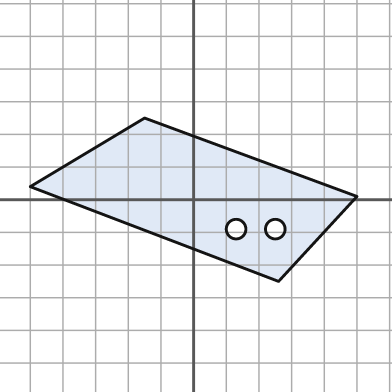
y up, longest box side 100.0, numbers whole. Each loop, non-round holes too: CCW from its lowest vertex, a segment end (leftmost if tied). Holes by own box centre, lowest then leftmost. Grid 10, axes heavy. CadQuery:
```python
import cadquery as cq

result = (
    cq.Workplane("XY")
    .moveTo(26.0, -25.0)
    .lineTo(50.0, 1.0)
    .lineTo(-15.0, 25.0)
    .lineTo(-50.0, 4.0)
    .close()
    .moveTo(13.0, -9.0)
    .circle(3.0)
    .moveTo(25.0, -9.0)
    .circle(3.0)
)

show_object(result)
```